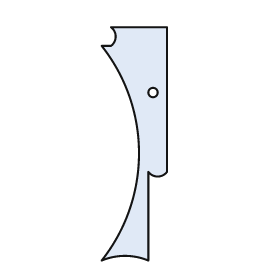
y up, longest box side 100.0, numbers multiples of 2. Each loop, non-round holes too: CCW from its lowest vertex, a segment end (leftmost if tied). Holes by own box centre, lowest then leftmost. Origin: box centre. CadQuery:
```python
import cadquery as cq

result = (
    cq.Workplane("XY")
    .moveTo(-14.0, -50.0)
    .threePointArc((-4.0, -48.0), (6.0, -50.0))
    .lineTo(6.0, -12.0)
    .threePointArc((10.0, -14.0), (14.0, -12.0))
    .lineTo(14.0, 50.0)
    .lineTo(-10.0, 50.0)
    .threePointArc((-8.0, 46.0), (-10.0, 42.0))
    .lineTo(-14.0, 42.0)
    .threePointArc((2.0, -4.0), (-14.0, -50.0))
    .close()
    .moveTo(8.0, 22.0)
    .circle(2.0)
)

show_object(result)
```